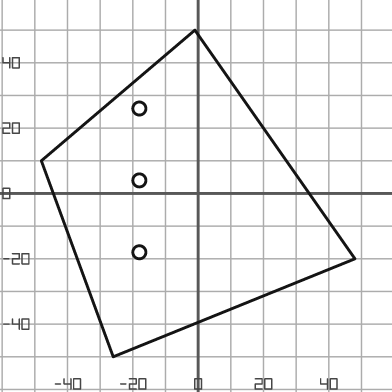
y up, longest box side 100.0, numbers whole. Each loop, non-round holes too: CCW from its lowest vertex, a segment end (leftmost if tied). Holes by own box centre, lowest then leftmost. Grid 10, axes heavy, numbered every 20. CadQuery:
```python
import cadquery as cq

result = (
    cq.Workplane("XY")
    .moveTo(-26.0, -50.0)
    .lineTo(48.0, -20.0)
    .lineTo(-1.0, 50.0)
    .lineTo(-48.0, 10.0)
    .close()
    .moveTo(-18.0, -18.0)
    .circle(2.0)
    .moveTo(-18.0, 4.0)
    .circle(2.0)
    .moveTo(-18.0, 26.0)
    .circle(2.0)
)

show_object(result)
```